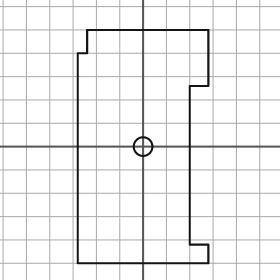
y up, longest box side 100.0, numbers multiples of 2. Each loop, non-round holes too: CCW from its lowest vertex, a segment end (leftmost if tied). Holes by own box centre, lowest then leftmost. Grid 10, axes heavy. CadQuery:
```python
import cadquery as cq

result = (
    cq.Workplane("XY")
    .moveTo(-28.0, -50.0)
    .lineTo(28.0, -50.0)
    .lineTo(28.0, -42.0)
    .lineTo(20.0, -42.0)
    .lineTo(20.0, 26.0)
    .lineTo(28.0, 26.0)
    .lineTo(28.0, 50.0)
    .lineTo(-24.0, 50.0)
    .lineTo(-24.0, 40.0)
    .lineTo(-28.0, 40.0)
    .close()
    .moveTo(0.0, 0.0)
    .circle(4.0)
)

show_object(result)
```